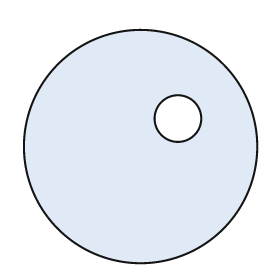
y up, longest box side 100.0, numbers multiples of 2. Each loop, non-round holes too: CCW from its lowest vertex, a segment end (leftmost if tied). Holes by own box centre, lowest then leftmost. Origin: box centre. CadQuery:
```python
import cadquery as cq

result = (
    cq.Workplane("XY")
    .moveTo(0.0, 0.0)
    .circle(50.0)
    .moveTo(16.0, 12.0)
    .circle(10.0)
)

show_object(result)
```